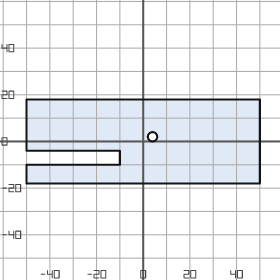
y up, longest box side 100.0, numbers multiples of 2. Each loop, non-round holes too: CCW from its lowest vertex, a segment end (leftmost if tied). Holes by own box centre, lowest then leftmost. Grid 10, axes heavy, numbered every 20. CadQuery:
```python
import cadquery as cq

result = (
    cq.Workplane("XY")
    .moveTo(-50.0, -18.0)
    .lineTo(50.0, -18.0)
    .lineTo(50.0, 18.0)
    .lineTo(-50.0, 18.0)
    .lineTo(-50.0, -4.0)
    .lineTo(-10.0, -4.0)
    .lineTo(-10.0, -10.0)
    .lineTo(-50.0, -10.0)
    .close()
    .moveTo(4.0, 2.0)
    .circle(2.0)
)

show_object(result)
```